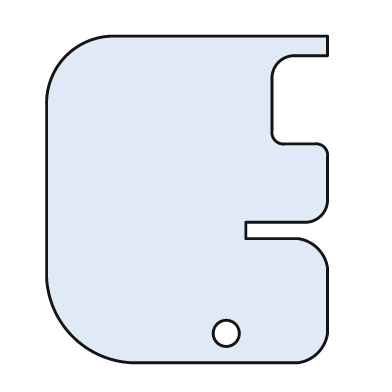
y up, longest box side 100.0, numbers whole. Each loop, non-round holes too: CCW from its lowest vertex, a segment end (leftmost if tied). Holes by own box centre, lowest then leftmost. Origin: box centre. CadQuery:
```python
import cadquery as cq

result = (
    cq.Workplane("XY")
    .moveTo(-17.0, -50.0)
    .lineTo(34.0, -50.0)
    .threePointArc((40.0, -47.0), (43.0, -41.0))
    .lineTo(43.0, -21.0)
    .threePointArc((40.0, -15.0), (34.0, -12.0))
    .lineTo(18.0, -12.0)
    .lineTo(18.0, -7.0)
    .lineTo(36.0, -7.0)
    .threePointArc((41.0, -5.0), (43.0, 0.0))
    .lineTo(43.0, 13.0)
    .threePointArc((42.0, 16.0), (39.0, 17.0))
    .lineTo(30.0, 17.0)
    .threePointArc((27.0, 18.0), (26.0, 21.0))
    .lineTo(26.0, 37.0)
    .threePointArc((28.0, 42.0), (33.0, 44.0))
    .lineTo(43.0, 44.0)
    .lineTo(43.0, 50.0)
    .lineTo(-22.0, 50.0)
    .threePointArc((-37.0, 44.0), (-43.0, 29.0))
    .lineTo(-43.0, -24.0)
    .threePointArc((-35.0, -42.0), (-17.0, -50.0))
    .close()
    .moveTo(12.0, -41.0)
    .circle(4.0)
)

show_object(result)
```